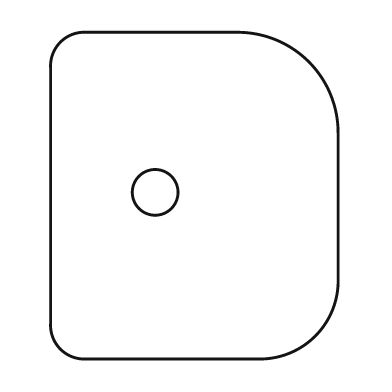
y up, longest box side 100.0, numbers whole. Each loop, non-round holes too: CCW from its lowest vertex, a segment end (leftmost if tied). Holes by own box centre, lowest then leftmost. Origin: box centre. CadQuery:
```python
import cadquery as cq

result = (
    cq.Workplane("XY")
    .moveTo(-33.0, -50.0)
    .lineTo(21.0, -50.0)
    .threePointArc((37.0, -43.0), (44.0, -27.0))
    .lineTo(44.0, 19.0)
    .threePointArc((35.0, 41.0), (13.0, 50.0))
    .lineTo(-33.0, 50.0)
    .threePointArc((-41.0, 47.0), (-44.0, 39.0))
    .lineTo(-44.0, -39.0)
    .threePointArc((-41.0, -47.0), (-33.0, -50.0))
    .close()
    .moveTo(-12.0, 1.0)
    .circle(7.0)
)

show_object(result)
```